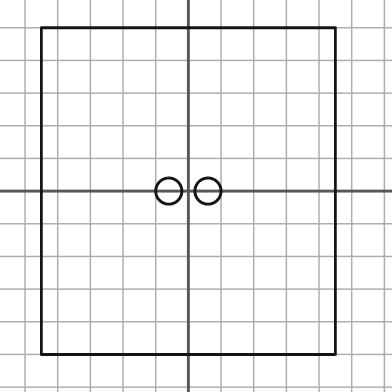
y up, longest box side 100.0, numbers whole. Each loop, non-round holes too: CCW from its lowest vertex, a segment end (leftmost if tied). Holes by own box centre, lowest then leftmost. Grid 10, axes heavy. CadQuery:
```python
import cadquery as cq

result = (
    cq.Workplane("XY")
    .moveTo(-45.0, -50.0)
    .lineTo(45.0, -50.0)
    .lineTo(45.0, 50.0)
    .lineTo(-45.0, 50.0)
    .close()
    .moveTo(-6.0, 0.0)
    .circle(4.0)
    .moveTo(6.0, 0.0)
    .circle(4.0)
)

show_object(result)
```